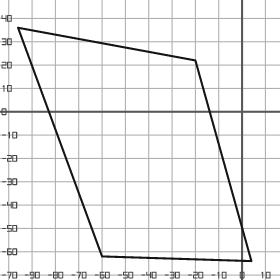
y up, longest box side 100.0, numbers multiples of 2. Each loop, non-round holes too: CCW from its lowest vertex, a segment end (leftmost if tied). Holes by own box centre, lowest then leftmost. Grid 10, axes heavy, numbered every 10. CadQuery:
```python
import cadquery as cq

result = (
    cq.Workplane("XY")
    .moveTo(4.0, -64.0)
    .lineTo(-20.0, 22.0)
    .lineTo(-96.0, 36.0)
    .lineTo(-60.0, -62.0)
    .close()
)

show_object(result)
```